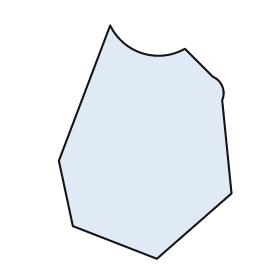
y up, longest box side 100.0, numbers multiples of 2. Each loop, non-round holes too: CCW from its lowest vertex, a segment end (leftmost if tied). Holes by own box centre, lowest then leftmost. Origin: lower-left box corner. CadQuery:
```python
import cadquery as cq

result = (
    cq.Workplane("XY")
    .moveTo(42.0, 0.0)
    .lineTo(74.0, 28.0)
    .lineTo(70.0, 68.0)
    .threePointArc((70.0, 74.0), (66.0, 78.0))
    .lineTo(54.0, 90.0)
    .threePointArc((36.0, 88.0), (22.0, 100.0))
    .lineTo(0.0, 42.0)
    .lineTo(6.0, 14.0)
    .close()
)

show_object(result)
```